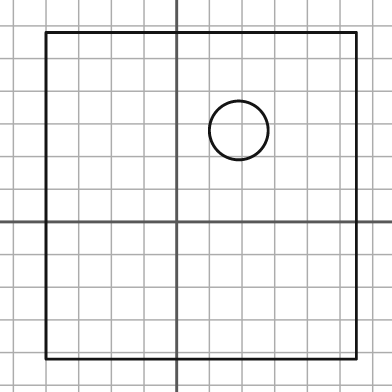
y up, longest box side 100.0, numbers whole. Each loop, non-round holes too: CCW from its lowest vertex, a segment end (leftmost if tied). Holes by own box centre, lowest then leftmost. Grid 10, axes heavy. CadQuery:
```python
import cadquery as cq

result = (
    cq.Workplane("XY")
    .moveTo(-40.0, -42.0)
    .lineTo(55.0, -42.0)
    .lineTo(55.0, 58.0)
    .lineTo(-40.0, 58.0)
    .close()
    .moveTo(19.0, 28.0)
    .circle(9.0)
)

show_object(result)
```